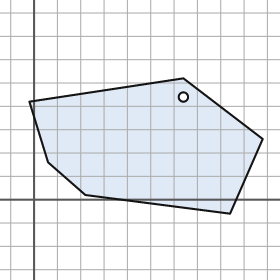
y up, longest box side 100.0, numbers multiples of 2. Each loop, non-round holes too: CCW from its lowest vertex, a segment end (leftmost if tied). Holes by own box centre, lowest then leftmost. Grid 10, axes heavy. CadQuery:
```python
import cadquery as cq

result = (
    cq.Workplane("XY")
    .moveTo(84.0, -6.0)
    .lineTo(98.0, 26.0)
    .lineTo(64.0, 52.0)
    .lineTo(-2.0, 42.0)
    .lineTo(6.0, 16.0)
    .lineTo(22.0, 2.0)
    .close()
    .moveTo(64.0, 44.0)
    .circle(2.0)
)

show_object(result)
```